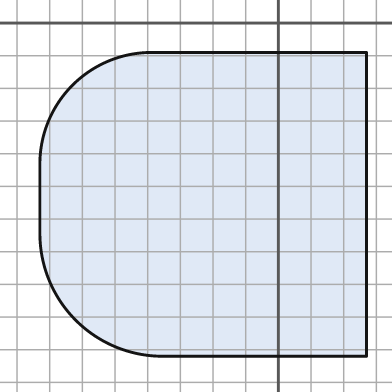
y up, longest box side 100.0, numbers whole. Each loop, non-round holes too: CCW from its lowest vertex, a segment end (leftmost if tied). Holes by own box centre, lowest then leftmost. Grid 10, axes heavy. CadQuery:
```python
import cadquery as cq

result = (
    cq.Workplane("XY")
    .moveTo(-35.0, -102.0)
    .lineTo(27.0, -102.0)
    .lineTo(27.0, -9.0)
    .lineTo(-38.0, -9.0)
    .threePointArc((-63.0, -19.0), (-73.0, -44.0))
    .lineTo(-73.0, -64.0)
    .threePointArc((-62.0, -91.0), (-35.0, -102.0))
    .close()
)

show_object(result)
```